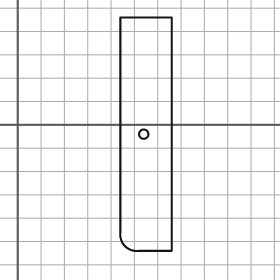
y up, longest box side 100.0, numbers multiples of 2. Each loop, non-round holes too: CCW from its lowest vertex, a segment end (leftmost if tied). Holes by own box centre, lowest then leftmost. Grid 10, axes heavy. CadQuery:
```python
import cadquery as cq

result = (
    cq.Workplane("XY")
    .moveTo(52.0, -54.0)
    .lineTo(66.0, -54.0)
    .lineTo(66.0, 46.0)
    .lineTo(44.0, 46.0)
    .lineTo(44.0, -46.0)
    .threePointArc((46.0, -52.0), (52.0, -54.0))
    .close()
    .moveTo(54.0, -4.0)
    .circle(2.0)
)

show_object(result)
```